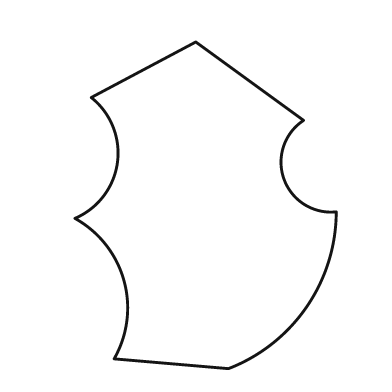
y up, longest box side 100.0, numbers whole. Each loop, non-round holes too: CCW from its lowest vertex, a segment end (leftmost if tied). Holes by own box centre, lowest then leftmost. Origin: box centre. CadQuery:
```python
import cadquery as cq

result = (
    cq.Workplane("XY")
    .moveTo(7.0, -50.0)
    .threePointArc((31.0, -31.0), (40.0, -2.0))
    .threePointArc((24.0, 8.0), (30.0, 26.0))
    .lineTo(-3.0, 50.0)
    .lineTo(-35.0, 33.0)
    .threePointArc((-27.0, 13.0), (-40.0, -4.0))
    .threePointArc((-25.0, -23.0), (-28.0, -47.0))
    .close()
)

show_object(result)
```